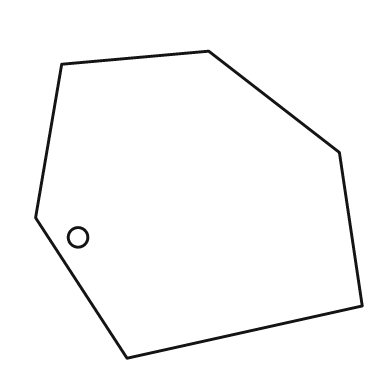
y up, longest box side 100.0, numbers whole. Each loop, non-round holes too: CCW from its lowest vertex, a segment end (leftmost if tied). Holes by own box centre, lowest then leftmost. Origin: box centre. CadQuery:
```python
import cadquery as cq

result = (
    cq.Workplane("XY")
    .moveTo(-22.0, -47.0)
    .lineTo(50.0, -31.0)
    .lineTo(43.0, 16.0)
    .lineTo(3.0, 47.0)
    .lineTo(-42.0, 43.0)
    .lineTo(-50.0, -4.0)
    .close()
    .moveTo(-37.0, -10.0)
    .circle(3.0)
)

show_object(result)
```